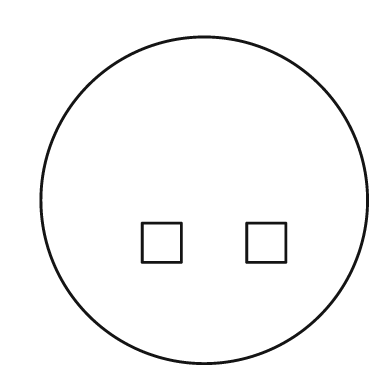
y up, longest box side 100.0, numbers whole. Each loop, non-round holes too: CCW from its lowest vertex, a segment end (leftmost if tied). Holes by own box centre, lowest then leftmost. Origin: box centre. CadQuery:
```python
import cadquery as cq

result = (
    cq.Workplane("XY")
    .moveTo(0.0, 0.0)
    .circle(50.0)
    .moveTo(-19.0, -19.0)
    .lineTo(-7.0, -19.0)
    .lineTo(-7.0, -7.0)
    .lineTo(-19.0, -7.0)
    .close()
    .moveTo(13.0, -19.0)
    .lineTo(25.0, -19.0)
    .lineTo(25.0, -7.0)
    .lineTo(13.0, -7.0)
    .close()
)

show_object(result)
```